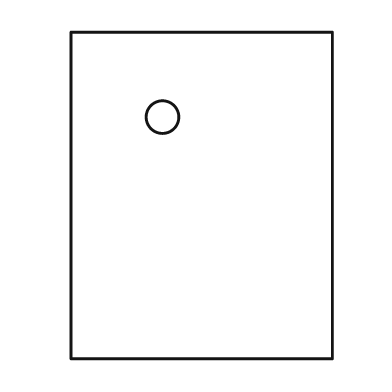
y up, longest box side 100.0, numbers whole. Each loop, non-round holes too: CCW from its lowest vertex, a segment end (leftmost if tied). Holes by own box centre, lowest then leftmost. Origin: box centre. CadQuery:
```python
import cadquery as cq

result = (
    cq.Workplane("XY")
    .moveTo(-40.0, -50.0)
    .lineTo(40.0, -50.0)
    .lineTo(40.0, 50.0)
    .lineTo(-40.0, 50.0)
    .close()
    .moveTo(-12.0, 24.0)
    .circle(5.0)
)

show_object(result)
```